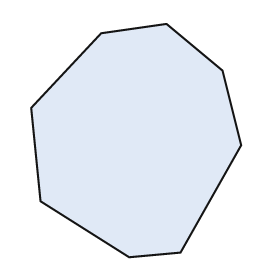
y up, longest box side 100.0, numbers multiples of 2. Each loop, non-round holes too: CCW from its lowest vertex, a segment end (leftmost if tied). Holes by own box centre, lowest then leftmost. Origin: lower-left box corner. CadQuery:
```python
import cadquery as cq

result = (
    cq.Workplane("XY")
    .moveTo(42.0, 0.0)
    .lineTo(64.0, 2.0)
    .lineTo(90.0, 48.0)
    .lineTo(82.0, 80.0)
    .lineTo(58.0, 100.0)
    .lineTo(30.0, 96.0)
    .lineTo(0.0, 64.0)
    .lineTo(4.0, 24.0)
    .close()
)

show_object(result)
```